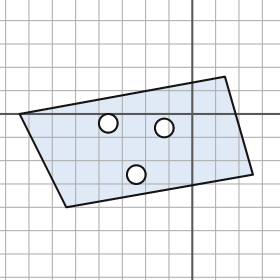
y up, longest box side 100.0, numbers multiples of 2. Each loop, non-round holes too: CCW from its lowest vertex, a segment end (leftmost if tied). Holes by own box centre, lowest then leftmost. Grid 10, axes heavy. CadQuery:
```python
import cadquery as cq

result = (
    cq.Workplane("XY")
    .moveTo(-54.0, -40.0)
    .lineTo(26.0, -26.0)
    .lineTo(14.0, 16.0)
    .lineTo(-74.0, 0.0)
    .close()
    .moveTo(-24.0, -26.0)
    .circle(4.0)
    .moveTo(-12.0, -6.0)
    .circle(4.0)
    .moveTo(-36.0, -4.0)
    .circle(4.0)
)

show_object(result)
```